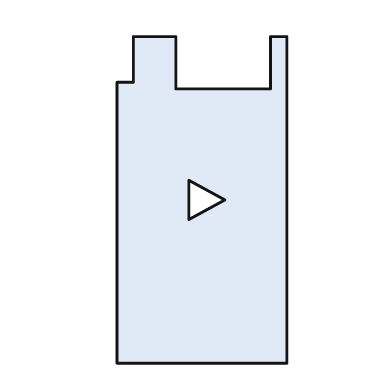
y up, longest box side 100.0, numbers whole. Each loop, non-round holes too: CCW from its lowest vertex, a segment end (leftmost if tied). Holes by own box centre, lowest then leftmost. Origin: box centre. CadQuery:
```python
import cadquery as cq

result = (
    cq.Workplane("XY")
    .moveTo(-26.0, -50.0)
    .lineTo(26.0, -50.0)
    .lineTo(26.0, 50.0)
    .lineTo(21.0, 50.0)
    .lineTo(21.0, 34.0)
    .lineTo(-8.0, 34.0)
    .lineTo(-8.0, 50.0)
    .lineTo(-21.0, 50.0)
    .lineTo(-21.0, 36.0)
    .lineTo(-26.0, 36.0)
    .close()
    .moveTo(-4.0, -6.0)
    .lineTo(7.0, 0.0)
    .lineTo(-4.0, 6.0)
    .close()
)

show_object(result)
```